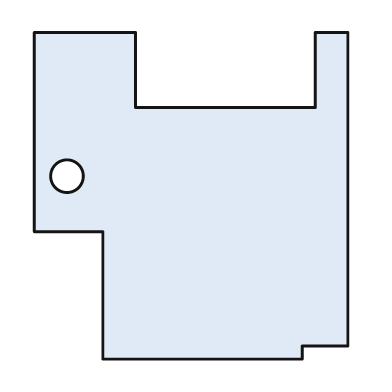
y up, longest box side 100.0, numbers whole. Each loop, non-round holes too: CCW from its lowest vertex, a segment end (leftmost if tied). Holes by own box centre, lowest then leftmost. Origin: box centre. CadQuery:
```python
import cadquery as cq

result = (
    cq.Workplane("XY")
    .moveTo(-27.0, -50.0)
    .lineTo(34.0, -50.0)
    .lineTo(34.0, -46.0)
    .lineTo(48.0, -46.0)
    .lineTo(48.0, 50.0)
    .lineTo(38.0, 50.0)
    .lineTo(38.0, 27.0)
    .lineTo(-17.0, 27.0)
    .lineTo(-17.0, 50.0)
    .lineTo(-48.0, 50.0)
    .lineTo(-48.0, -11.0)
    .lineTo(-27.0, -11.0)
    .close()
    .moveTo(-38.0, 6.0)
    .circle(5.0)
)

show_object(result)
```